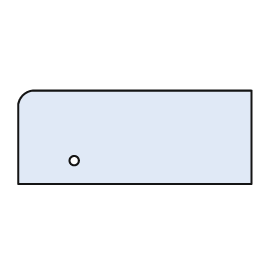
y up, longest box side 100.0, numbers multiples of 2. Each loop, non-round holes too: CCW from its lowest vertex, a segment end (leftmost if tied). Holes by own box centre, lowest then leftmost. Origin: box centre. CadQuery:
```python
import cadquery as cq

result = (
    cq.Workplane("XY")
    .moveTo(-50.0, -20.0)
    .lineTo(50.0, -20.0)
    .lineTo(50.0, 20.0)
    .lineTo(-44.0, 20.0)
    .threePointArc((-48.0, 18.0), (-50.0, 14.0))
    .close()
    .moveTo(-26.0, -10.0)
    .circle(2.0)
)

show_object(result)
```